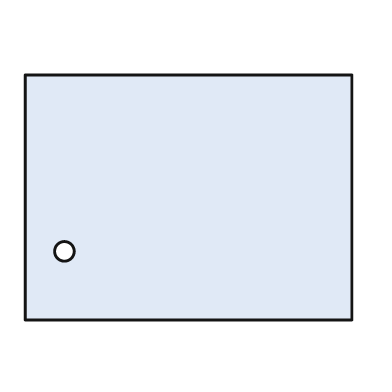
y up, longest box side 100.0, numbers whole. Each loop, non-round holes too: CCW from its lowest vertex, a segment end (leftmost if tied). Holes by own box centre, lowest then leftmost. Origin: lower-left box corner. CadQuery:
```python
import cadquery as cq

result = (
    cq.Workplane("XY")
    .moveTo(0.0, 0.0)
    .lineTo(100.0, 0.0)
    .lineTo(100.0, 75.0)
    .lineTo(0.0, 75.0)
    .close()
    .moveTo(12.0, 21.0)
    .circle(3.0)
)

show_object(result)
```